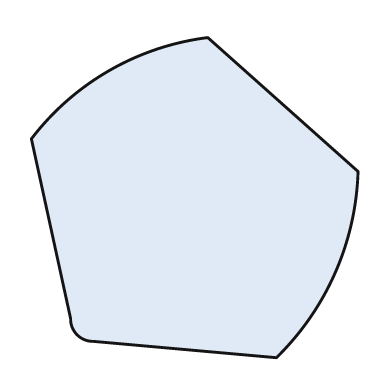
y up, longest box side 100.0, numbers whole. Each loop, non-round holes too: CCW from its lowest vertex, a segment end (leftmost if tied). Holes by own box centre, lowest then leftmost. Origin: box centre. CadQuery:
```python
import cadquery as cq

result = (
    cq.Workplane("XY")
    .moveTo(25.0, -49.0)
    .threePointArc((43.0, -23.0), (50.0, 8.0))
    .lineTo(4.0, 49.0)
    .threePointArc((-26.0, 39.0), (-50.0, 18.0))
    .lineTo(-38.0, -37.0)
    .threePointArc((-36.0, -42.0), (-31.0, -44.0))
    .close()
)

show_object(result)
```